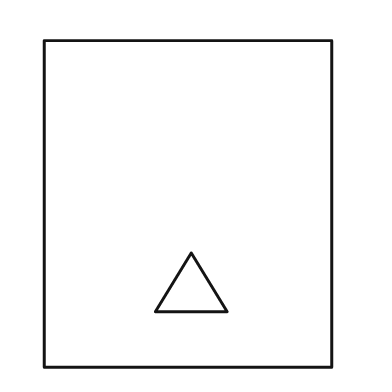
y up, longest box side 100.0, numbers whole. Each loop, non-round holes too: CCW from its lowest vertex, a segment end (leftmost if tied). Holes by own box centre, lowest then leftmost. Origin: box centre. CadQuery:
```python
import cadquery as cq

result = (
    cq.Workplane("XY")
    .moveTo(-44.0, -50.0)
    .lineTo(44.0, -50.0)
    .lineTo(44.0, 50.0)
    .lineTo(-44.0, 50.0)
    .close()
    .moveTo(-10.0, -33.0)
    .lineTo(12.0, -33.0)
    .lineTo(1.0, -15.0)
    .close()
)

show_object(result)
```